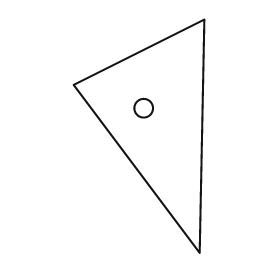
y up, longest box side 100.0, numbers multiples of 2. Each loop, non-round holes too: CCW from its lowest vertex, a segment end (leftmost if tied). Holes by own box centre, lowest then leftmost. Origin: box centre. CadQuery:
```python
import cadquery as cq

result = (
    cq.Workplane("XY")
    .moveTo(26.0, -50.0)
    .lineTo(28.0, 50.0)
    .lineTo(-28.0, 22.0)
    .close()
    .moveTo(2.0, 12.0)
    .circle(4.0)
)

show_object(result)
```